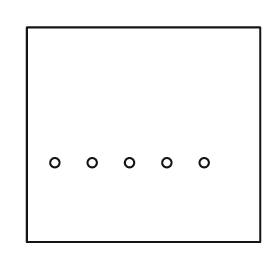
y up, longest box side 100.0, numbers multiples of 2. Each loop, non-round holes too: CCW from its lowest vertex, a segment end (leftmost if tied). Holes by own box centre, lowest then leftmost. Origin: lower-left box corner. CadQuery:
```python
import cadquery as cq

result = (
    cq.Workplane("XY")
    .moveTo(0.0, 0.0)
    .lineTo(100.0, 0.0)
    .lineTo(100.0, 92.0)
    .lineTo(0.0, 92.0)
    .close()
    .moveTo(12.0, 34.0)
    .circle(2.0)
    .moveTo(28.0, 34.0)
    .circle(2.0)
    .moveTo(44.0, 34.0)
    .circle(2.0)
    .moveTo(60.0, 34.0)
    .circle(2.0)
    .moveTo(76.0, 34.0)
    .circle(2.0)
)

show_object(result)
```